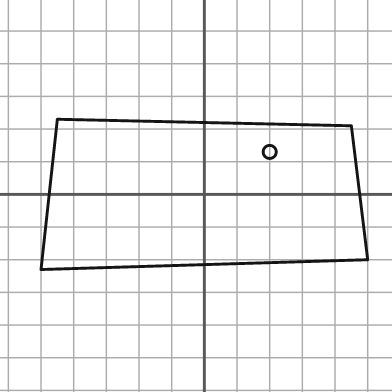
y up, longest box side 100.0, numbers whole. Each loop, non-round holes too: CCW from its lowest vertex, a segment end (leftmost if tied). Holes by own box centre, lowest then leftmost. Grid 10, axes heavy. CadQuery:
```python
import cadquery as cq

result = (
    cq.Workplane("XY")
    .moveTo(-50.0, -23.0)
    .lineTo(50.0, -20.0)
    .lineTo(45.0, 21.0)
    .lineTo(-45.0, 23.0)
    .close()
    .moveTo(20.0, 13.0)
    .circle(2.0)
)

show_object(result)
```